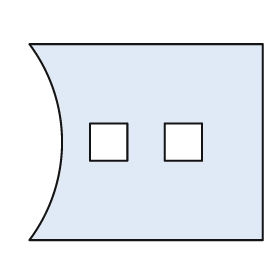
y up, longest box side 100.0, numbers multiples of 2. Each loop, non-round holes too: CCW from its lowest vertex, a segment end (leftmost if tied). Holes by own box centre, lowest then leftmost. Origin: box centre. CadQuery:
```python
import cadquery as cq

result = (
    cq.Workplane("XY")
    .moveTo(-50.0, -42.0)
    .lineTo(50.0, -42.0)
    .lineTo(50.0, 42.0)
    .lineTo(-50.0, 42.0)
    .threePointArc((-36.0, 0.0), (-50.0, -42.0))
    .close()
    .moveTo(-24.0, -8.0)
    .lineTo(-8.0, -8.0)
    .lineTo(-8.0, 8.0)
    .lineTo(-24.0, 8.0)
    .close()
    .moveTo(8.0, -8.0)
    .lineTo(24.0, -8.0)
    .lineTo(24.0, 8.0)
    .lineTo(8.0, 8.0)
    .close()
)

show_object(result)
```